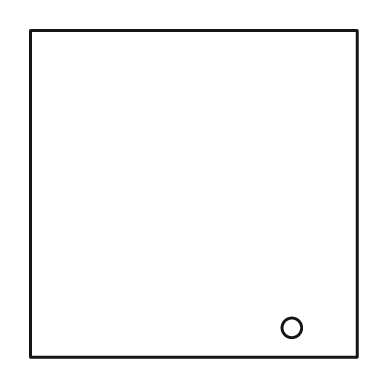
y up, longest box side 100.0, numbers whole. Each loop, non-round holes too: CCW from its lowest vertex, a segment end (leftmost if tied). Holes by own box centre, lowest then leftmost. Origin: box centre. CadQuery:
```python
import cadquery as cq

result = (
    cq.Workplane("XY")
    .moveTo(-50.0, -50.0)
    .lineTo(50.0, -50.0)
    .lineTo(50.0, 50.0)
    .lineTo(-50.0, 50.0)
    .close()
    .moveTo(30.0, -41.0)
    .circle(3.0)
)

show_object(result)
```